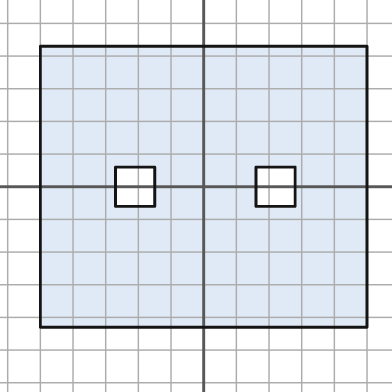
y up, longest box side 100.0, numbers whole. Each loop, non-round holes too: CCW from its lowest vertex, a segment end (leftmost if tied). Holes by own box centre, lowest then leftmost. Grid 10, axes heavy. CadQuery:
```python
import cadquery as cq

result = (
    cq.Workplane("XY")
    .moveTo(-50.0, -43.0)
    .lineTo(50.0, -43.0)
    .lineTo(50.0, 43.0)
    .lineTo(-50.0, 43.0)
    .close()
    .moveTo(-27.0, -6.0)
    .lineTo(-15.0, -6.0)
    .lineTo(-15.0, 6.0)
    .lineTo(-27.0, 6.0)
    .close()
    .moveTo(16.0, -6.0)
    .lineTo(28.0, -6.0)
    .lineTo(28.0, 6.0)
    .lineTo(16.0, 6.0)
    .close()
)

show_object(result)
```